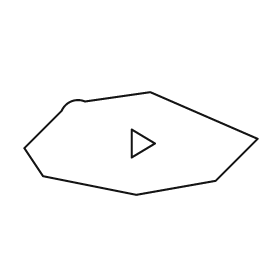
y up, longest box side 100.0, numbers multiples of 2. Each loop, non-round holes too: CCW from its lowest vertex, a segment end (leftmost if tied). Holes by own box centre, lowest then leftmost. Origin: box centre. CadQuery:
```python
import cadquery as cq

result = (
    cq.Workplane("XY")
    .moveTo(-2.0, -22.0)
    .lineTo(32.0, -16.0)
    .lineTo(50.0, 2.0)
    .lineTo(4.0, 22.0)
    .lineTo(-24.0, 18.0)
    .threePointArc((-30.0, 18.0), (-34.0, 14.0))
    .lineTo(-50.0, -2.0)
    .lineTo(-42.0, -14.0)
    .close()
    .moveTo(-4.0, -6.0)
    .lineTo(6.0, 0.0)
    .lineTo(-4.0, 6.0)
    .close()
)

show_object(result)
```